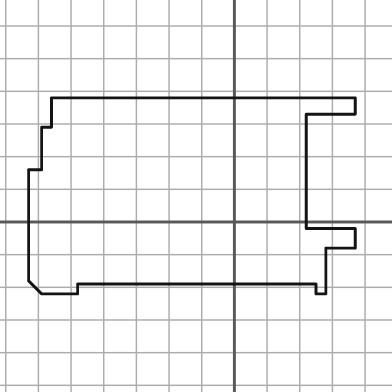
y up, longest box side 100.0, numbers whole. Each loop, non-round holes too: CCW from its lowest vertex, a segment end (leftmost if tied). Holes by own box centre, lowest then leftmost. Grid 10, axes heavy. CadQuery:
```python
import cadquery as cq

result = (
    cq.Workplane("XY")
    .moveTo(-59.0, -22.0)
    .lineTo(-48.0, -22.0)
    .lineTo(-48.0, -19.0)
    .lineTo(25.0, -19.0)
    .lineTo(25.0, -22.0)
    .lineTo(28.0, -22.0)
    .lineTo(28.0, -8.0)
    .lineTo(37.0, -8.0)
    .lineTo(37.0, -2.0)
    .lineTo(22.0, -2.0)
    .lineTo(22.0, 33.0)
    .lineTo(37.0, 33.0)
    .lineTo(37.0, 38.0)
    .lineTo(-56.0, 38.0)
    .lineTo(-56.0, 29.0)
    .lineTo(-59.0, 29.0)
    .lineTo(-59.0, 16.0)
    .lineTo(-63.0, 16.0)
    .lineTo(-63.0, -18.0)
    .close()
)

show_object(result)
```